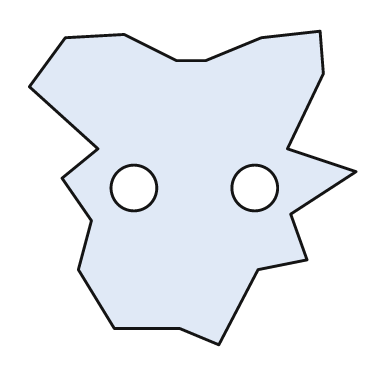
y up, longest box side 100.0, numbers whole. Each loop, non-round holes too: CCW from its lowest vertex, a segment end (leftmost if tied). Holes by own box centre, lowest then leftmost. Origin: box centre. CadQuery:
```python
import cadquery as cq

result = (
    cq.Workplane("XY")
    .moveTo(8.0, -48.0)
    .lineTo(20.0, -25.0)
    .lineTo(35.0, -22.0)
    .lineTo(30.0, -8.0)
    .lineTo(50.0, 5.0)
    .lineTo(29.0, 12.0)
    .lineTo(40.0, 35.0)
    .lineTo(39.0, 48.0)
    .lineTo(21.0, 46.0)
    .lineTo(4.0, 39.0)
    .lineTo(-5.0, 39.0)
    .lineTo(-21.0, 47.0)
    .lineTo(-39.0, 46.0)
    .lineTo(-50.0, 31.0)
    .lineTo(-29.0, 12.0)
    .lineTo(-40.0, 3.0)
    .lineTo(-31.0, -10.0)
    .lineTo(-35.0, -25.0)
    .lineTo(-24.0, -43.0)
    .lineTo(-4.0, -43.0)
    .close()
    .moveTo(-18.0, 0.0)
    .circle(7.0)
    .moveTo(19.0, 0.0)
    .circle(7.0)
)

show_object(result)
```